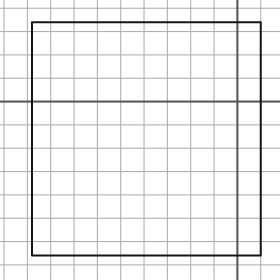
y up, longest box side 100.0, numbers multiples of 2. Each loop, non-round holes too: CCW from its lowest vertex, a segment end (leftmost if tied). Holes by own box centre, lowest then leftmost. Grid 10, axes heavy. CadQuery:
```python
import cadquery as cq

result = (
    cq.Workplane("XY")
    .moveTo(-88.0, -66.0)
    .lineTo(10.0, -66.0)
    .lineTo(10.0, 34.0)
    .lineTo(-88.0, 34.0)
    .close()
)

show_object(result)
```